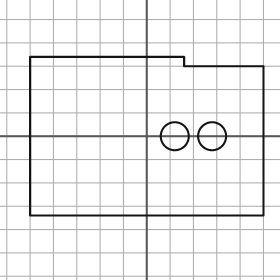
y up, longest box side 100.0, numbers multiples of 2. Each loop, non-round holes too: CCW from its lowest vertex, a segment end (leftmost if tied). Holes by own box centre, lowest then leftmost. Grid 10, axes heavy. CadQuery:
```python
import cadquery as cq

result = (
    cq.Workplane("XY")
    .moveTo(-50.0, -34.0)
    .lineTo(50.0, -34.0)
    .lineTo(50.0, 30.0)
    .lineTo(16.0, 30.0)
    .lineTo(16.0, 34.0)
    .lineTo(-50.0, 34.0)
    .close()
    .moveTo(12.0, 0.0)
    .circle(6.0)
    .moveTo(28.0, 0.0)
    .circle(6.0)
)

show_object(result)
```